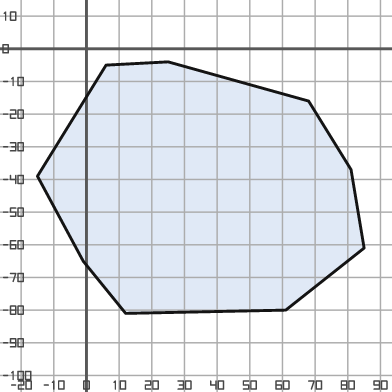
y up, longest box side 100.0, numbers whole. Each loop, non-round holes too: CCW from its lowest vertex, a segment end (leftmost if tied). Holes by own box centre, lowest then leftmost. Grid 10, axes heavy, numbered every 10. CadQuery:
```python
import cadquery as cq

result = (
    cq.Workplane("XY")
    .moveTo(12.0, -81.0)
    .lineTo(61.0, -80.0)
    .lineTo(85.0, -61.0)
    .lineTo(81.0, -37.0)
    .lineTo(68.0, -16.0)
    .lineTo(25.0, -4.0)
    .lineTo(6.0, -5.0)
    .lineTo(-15.0, -39.0)
    .lineTo(-1.0, -65.0)
    .close()
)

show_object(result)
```